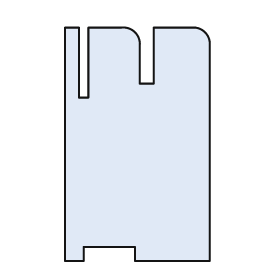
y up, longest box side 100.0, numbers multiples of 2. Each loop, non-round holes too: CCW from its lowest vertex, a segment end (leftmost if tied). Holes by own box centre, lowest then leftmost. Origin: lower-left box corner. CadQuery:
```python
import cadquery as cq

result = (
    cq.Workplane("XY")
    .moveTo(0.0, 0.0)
    .lineTo(8.0, 0.0)
    .lineTo(8.0, 6.0)
    .lineTo(30.0, 6.0)
    .lineTo(30.0, 0.0)
    .lineTo(62.0, 0.0)
    .lineTo(62.0, 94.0)
    .threePointArc((60.0, 98.0), (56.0, 100.0))
    .lineTo(38.0, 100.0)
    .lineTo(38.0, 76.0)
    .lineTo(32.0, 76.0)
    .lineTo(32.0, 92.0)
    .threePointArc((30.0, 98.0), (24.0, 100.0))
    .lineTo(10.0, 100.0)
    .lineTo(10.0, 70.0)
    .lineTo(6.0, 70.0)
    .lineTo(6.0, 100.0)
    .lineTo(0.0, 100.0)
    .close()
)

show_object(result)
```